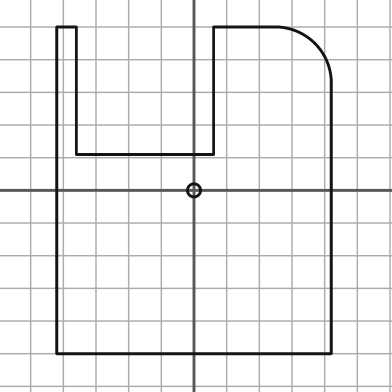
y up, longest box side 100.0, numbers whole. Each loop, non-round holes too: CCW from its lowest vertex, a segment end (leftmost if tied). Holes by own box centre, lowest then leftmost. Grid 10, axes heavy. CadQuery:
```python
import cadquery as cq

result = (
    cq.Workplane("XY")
    .moveTo(-42.0, -50.0)
    .lineTo(42.0, -50.0)
    .lineTo(42.0, 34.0)
    .threePointArc((37.0, 45.0), (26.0, 50.0))
    .lineTo(6.0, 50.0)
    .lineTo(6.0, 11.0)
    .lineTo(-36.0, 11.0)
    .lineTo(-36.0, 50.0)
    .lineTo(-42.0, 50.0)
    .close()
    .moveTo(0.0, 0.0)
    .circle(2.0)
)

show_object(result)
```